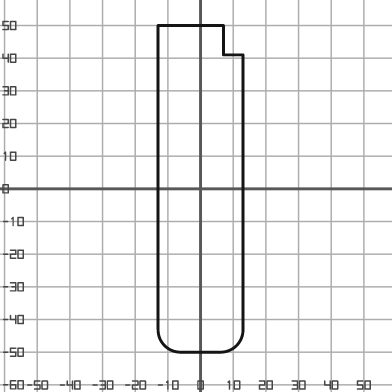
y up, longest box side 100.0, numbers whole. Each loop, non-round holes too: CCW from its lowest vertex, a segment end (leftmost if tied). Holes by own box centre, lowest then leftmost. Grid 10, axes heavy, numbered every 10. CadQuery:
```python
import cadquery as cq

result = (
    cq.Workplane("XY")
    .moveTo(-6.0, -50.0)
    .lineTo(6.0, -50.0)
    .threePointArc((11.0, -48.0), (13.0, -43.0))
    .lineTo(13.0, 41.0)
    .lineTo(7.0, 41.0)
    .lineTo(7.0, 50.0)
    .lineTo(-13.0, 50.0)
    .lineTo(-13.0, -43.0)
    .threePointArc((-11.0, -48.0), (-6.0, -50.0))
    .close()
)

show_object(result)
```